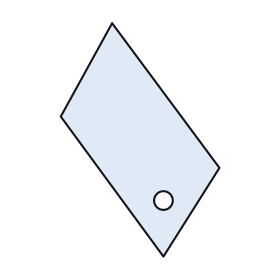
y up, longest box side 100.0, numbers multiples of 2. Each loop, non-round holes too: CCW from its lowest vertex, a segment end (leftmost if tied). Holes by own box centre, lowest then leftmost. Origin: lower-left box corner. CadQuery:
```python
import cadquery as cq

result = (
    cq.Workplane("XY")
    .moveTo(44.0, 0.0)
    .lineTo(68.0, 38.0)
    .lineTo(22.0, 100.0)
    .lineTo(0.0, 60.0)
    .close()
    .moveTo(44.0, 24.0)
    .circle(4.0)
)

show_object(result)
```